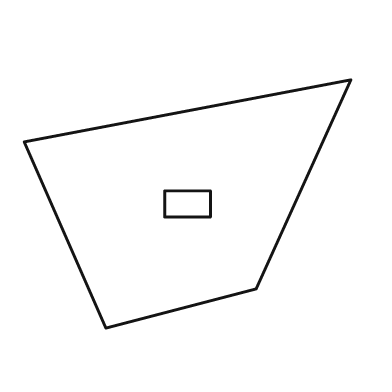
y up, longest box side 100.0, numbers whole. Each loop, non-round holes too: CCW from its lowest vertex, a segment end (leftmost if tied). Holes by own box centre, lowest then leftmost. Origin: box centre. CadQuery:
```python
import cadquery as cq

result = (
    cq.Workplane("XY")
    .moveTo(-25.0, -38.0)
    .lineTo(21.0, -26.0)
    .lineTo(50.0, 38.0)
    .lineTo(-50.0, 19.0)
    .close()
    .moveTo(-7.0, -4.0)
    .lineTo(7.0, -4.0)
    .lineTo(7.0, 4.0)
    .lineTo(-7.0, 4.0)
    .close()
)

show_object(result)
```